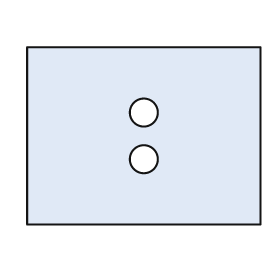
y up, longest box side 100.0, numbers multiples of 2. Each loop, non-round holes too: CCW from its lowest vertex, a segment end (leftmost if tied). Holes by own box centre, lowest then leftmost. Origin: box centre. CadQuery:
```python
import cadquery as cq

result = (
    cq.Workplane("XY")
    .moveTo(-50.0, -38.0)
    .lineTo(50.0, -38.0)
    .lineTo(50.0, 38.0)
    .lineTo(-50.0, 38.0)
    .close()
    .moveTo(0.0, -10.0)
    .circle(6.0)
    .moveTo(0.0, 10.0)
    .circle(6.0)
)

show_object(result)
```